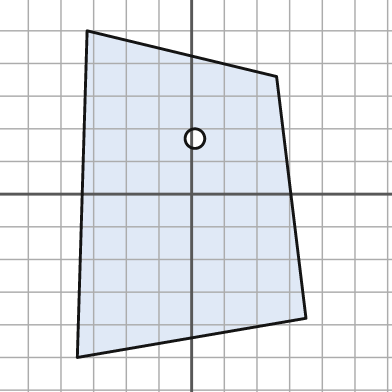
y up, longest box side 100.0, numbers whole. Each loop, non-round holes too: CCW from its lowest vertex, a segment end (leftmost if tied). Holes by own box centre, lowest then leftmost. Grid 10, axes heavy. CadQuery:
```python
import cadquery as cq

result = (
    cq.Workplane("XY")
    .moveTo(-35.0, -50.0)
    .lineTo(35.0, -38.0)
    .lineTo(26.0, 36.0)
    .lineTo(-32.0, 50.0)
    .close()
    .moveTo(1.0, 17.0)
    .circle(3.0)
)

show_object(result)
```